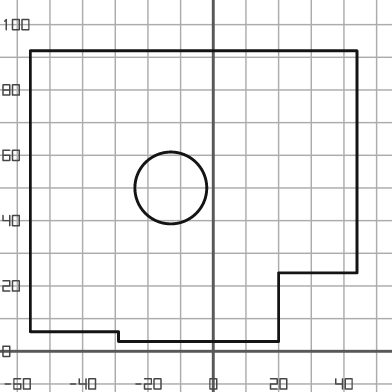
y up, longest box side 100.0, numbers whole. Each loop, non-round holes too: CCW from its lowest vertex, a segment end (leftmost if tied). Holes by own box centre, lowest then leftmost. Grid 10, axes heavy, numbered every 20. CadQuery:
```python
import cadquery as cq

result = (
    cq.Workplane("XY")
    .moveTo(-29.0, 3.0)
    .lineTo(20.0, 3.0)
    .lineTo(20.0, 24.0)
    .lineTo(44.0, 24.0)
    .lineTo(44.0, 92.0)
    .lineTo(-56.0, 92.0)
    .lineTo(-56.0, 6.0)
    .lineTo(-29.0, 6.0)
    .close()
    .moveTo(-13.0, 50.0)
    .circle(11.0)
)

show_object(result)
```